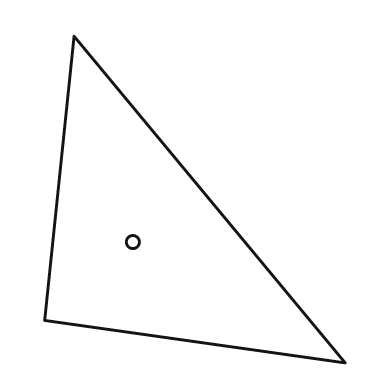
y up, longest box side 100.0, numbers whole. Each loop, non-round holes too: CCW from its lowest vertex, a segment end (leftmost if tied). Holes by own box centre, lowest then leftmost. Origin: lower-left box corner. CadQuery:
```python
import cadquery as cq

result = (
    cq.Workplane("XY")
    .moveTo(92.0, 0.0)
    .lineTo(9.0, 100.0)
    .lineTo(0.0, 13.0)
    .close()
    .moveTo(27.0, 37.0)
    .circle(2.0)
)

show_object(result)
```